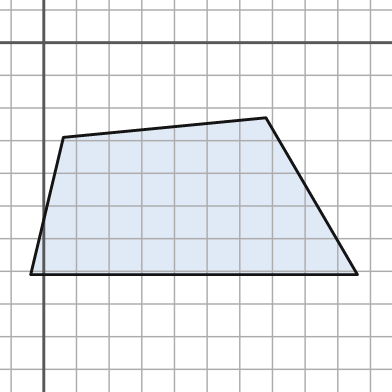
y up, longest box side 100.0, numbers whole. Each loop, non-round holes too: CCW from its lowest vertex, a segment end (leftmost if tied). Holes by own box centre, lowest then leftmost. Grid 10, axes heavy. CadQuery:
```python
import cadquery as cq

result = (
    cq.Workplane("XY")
    .moveTo(-4.0, -71.0)
    .lineTo(96.0, -71.0)
    .lineTo(68.0, -23.0)
    .lineTo(6.0, -29.0)
    .close()
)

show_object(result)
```